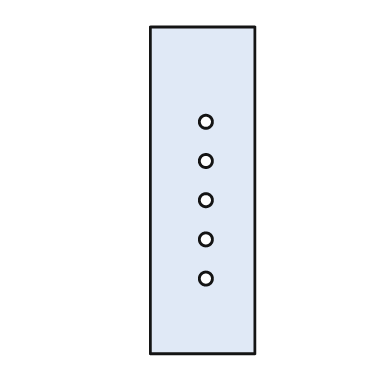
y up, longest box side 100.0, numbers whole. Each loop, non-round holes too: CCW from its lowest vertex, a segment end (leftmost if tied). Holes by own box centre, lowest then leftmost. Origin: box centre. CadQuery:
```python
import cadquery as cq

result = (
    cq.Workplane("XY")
    .moveTo(-16.0, -50.0)
    .lineTo(16.0, -50.0)
    .lineTo(16.0, 50.0)
    .lineTo(-16.0, 50.0)
    .close()
    .moveTo(1.0, -27.0)
    .circle(2.0)
    .moveTo(1.0, -15.0)
    .circle(2.0)
    .moveTo(1.0, -3.0)
    .circle(2.0)
    .moveTo(1.0, 9.0)
    .circle(2.0)
    .moveTo(1.0, 21.0)
    .circle(2.0)
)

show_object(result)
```